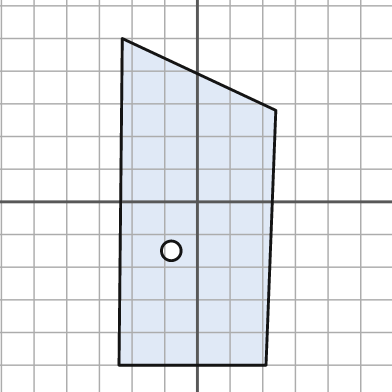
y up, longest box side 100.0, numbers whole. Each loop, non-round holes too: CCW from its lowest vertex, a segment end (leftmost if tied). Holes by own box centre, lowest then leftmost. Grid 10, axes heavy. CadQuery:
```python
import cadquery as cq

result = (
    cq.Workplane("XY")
    .moveTo(-24.0, -50.0)
    .lineTo(21.0, -50.0)
    .lineTo(24.0, 28.0)
    .lineTo(-23.0, 50.0)
    .close()
    .moveTo(-8.0, -15.0)
    .circle(3.0)
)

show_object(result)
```